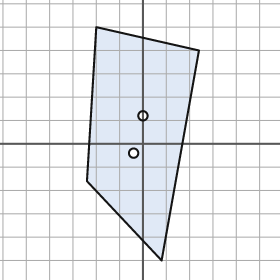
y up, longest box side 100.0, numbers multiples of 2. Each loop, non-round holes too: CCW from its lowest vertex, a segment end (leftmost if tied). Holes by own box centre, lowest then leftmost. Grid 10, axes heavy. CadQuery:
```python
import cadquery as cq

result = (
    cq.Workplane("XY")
    .moveTo(8.0, -50.0)
    .lineTo(24.0, 40.0)
    .lineTo(-20.0, 50.0)
    .lineTo(-24.0, -16.0)
    .close()
    .moveTo(-4.0, -4.0)
    .circle(2.0)
    .moveTo(0.0, 12.0)
    .circle(2.0)
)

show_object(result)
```